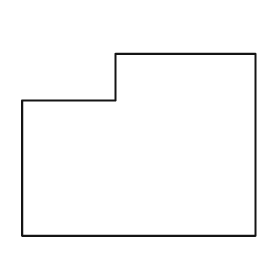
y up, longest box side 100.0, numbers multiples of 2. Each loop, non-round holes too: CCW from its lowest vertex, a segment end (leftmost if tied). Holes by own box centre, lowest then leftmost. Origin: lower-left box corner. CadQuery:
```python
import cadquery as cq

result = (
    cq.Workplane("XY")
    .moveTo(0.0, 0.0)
    .lineTo(100.0, 0.0)
    .lineTo(100.0, 78.0)
    .lineTo(40.0, 78.0)
    .lineTo(40.0, 58.0)
    .lineTo(0.0, 58.0)
    .close()
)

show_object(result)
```